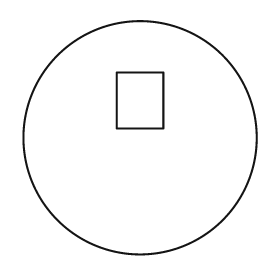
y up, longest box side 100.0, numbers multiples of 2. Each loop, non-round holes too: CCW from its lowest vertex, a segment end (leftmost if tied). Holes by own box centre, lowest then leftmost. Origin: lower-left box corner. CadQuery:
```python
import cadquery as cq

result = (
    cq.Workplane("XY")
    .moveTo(50.0, 50.0)
    .circle(50.0)
    .moveTo(40.0, 54.0)
    .lineTo(60.0, 54.0)
    .lineTo(60.0, 78.0)
    .lineTo(40.0, 78.0)
    .close()
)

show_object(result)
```